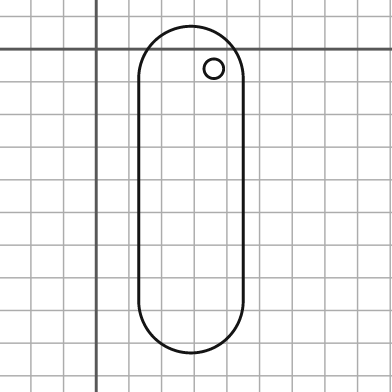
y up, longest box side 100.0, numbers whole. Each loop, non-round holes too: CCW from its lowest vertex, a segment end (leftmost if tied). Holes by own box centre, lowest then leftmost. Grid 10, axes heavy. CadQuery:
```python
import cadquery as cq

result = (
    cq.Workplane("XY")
    .moveTo(13.0, -77.0)
    .threePointArc((29.0, -93.0), (45.0, -77.0))
    .lineTo(45.0, -9.0)
    .threePointArc((29.0, 7.0), (13.0, -9.0))
    .close()
    .moveTo(36.0, -6.0)
    .circle(3.0)
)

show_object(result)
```